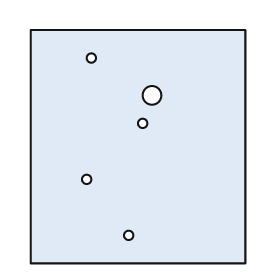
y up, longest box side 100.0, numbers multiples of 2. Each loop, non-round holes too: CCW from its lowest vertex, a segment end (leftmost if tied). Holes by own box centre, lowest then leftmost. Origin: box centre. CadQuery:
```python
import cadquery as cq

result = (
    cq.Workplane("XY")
    .moveTo(-46.0, -50.0)
    .lineTo(46.0, -50.0)
    .lineTo(46.0, 50.0)
    .lineTo(-46.0, 50.0)
    .close()
    .moveTo(-4.0, -38.0)
    .circle(2.0)
    .moveTo(-22.0, -14.0)
    .circle(2.0)
    .moveTo(2.0, 10.0)
    .circle(2.0)
    .moveTo(6.0, 22.0)
    .circle(4.0)
    .moveTo(-20.0, 38.0)
    .circle(2.0)
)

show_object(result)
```